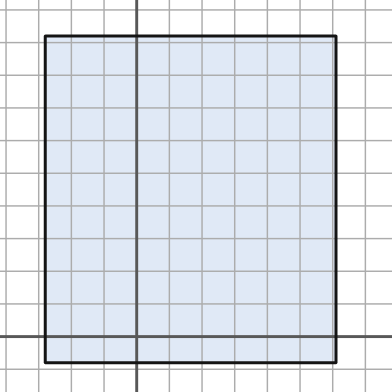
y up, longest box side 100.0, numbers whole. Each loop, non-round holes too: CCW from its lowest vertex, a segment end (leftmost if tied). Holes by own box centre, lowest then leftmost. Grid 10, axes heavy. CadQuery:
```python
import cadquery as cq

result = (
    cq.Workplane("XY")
    .moveTo(-28.0, -8.0)
    .lineTo(61.0, -8.0)
    .lineTo(61.0, 92.0)
    .lineTo(-28.0, 92.0)
    .close()
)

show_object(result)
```